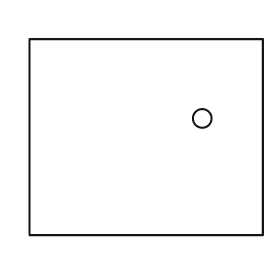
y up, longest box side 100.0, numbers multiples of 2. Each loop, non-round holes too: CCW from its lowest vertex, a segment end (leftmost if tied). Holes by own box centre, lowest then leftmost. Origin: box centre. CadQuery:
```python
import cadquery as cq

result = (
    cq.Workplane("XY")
    .moveTo(-50.0, -42.0)
    .lineTo(50.0, -42.0)
    .lineTo(50.0, 42.0)
    .lineTo(-50.0, 42.0)
    .close()
    .moveTo(24.0, 8.0)
    .circle(4.0)
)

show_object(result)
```